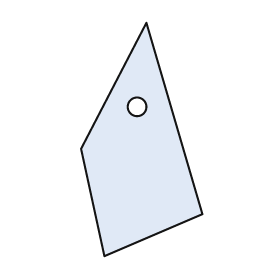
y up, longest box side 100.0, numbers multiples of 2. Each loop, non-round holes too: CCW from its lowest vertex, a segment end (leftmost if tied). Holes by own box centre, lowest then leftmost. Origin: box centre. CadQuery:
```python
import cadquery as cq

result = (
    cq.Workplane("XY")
    .moveTo(-16.0, -50.0)
    .lineTo(26.0, -32.0)
    .lineTo(2.0, 50.0)
    .lineTo(-26.0, -4.0)
    .close()
    .moveTo(-2.0, 14.0)
    .circle(4.0)
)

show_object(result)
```